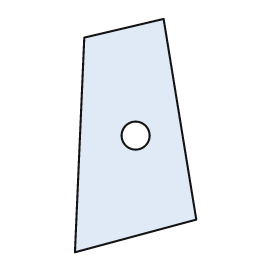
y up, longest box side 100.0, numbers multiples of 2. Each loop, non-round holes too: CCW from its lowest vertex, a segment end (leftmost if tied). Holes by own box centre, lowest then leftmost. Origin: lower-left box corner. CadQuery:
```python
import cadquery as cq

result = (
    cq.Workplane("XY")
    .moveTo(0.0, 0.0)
    .lineTo(52.0, 14.0)
    .lineTo(38.0, 100.0)
    .lineTo(4.0, 92.0)
    .close()
    .moveTo(26.0, 50.0)
    .circle(6.0)
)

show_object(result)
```